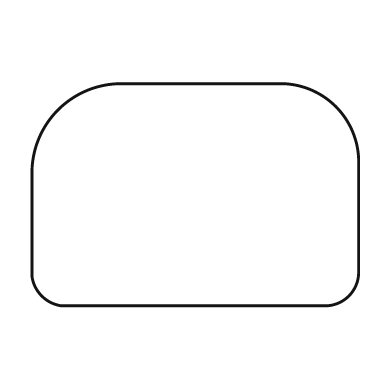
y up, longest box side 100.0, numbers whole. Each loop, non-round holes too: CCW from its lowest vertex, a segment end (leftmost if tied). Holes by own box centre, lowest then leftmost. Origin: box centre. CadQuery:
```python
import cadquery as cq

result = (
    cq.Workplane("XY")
    .moveTo(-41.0, -34.0)
    .lineTo(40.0, -34.0)
    .threePointArc((47.0, -31.0), (50.0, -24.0))
    .lineTo(50.0, 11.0)
    .threePointArc((43.0, 27.0), (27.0, 34.0))
    .lineTo(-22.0, 34.0)
    .threePointArc((-42.0, 26.0), (-50.0, 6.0))
    .lineTo(-50.0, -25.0)
    .threePointArc((-47.0, -31.0), (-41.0, -34.0))
    .close()
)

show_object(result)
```